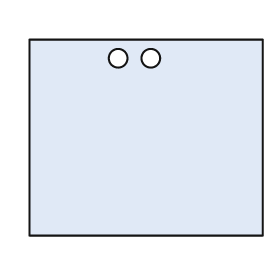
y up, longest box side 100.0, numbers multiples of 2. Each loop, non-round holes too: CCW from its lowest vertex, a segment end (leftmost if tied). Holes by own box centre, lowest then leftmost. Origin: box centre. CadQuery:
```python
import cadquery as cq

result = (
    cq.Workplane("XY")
    .moveTo(-50.0, -42.0)
    .lineTo(50.0, -42.0)
    .lineTo(50.0, 42.0)
    .lineTo(-50.0, 42.0)
    .close()
    .moveTo(-12.0, 34.0)
    .circle(4.0)
    .moveTo(2.0, 34.0)
    .circle(4.0)
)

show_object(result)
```